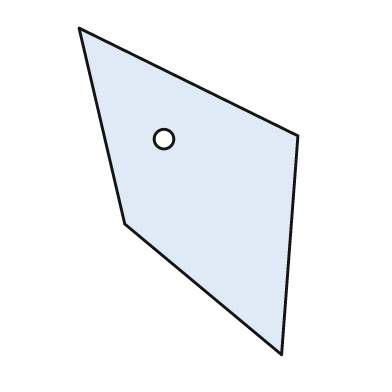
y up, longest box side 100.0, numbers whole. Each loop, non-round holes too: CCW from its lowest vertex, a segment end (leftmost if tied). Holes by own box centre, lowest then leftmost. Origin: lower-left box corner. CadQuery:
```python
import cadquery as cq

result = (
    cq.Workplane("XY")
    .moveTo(62.0, 0.0)
    .lineTo(67.0, 67.0)
    .lineTo(0.0, 100.0)
    .lineTo(14.0, 40.0)
    .close()
    .moveTo(26.0, 66.0)
    .circle(3.0)
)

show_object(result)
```